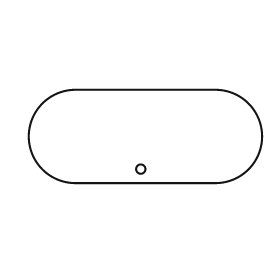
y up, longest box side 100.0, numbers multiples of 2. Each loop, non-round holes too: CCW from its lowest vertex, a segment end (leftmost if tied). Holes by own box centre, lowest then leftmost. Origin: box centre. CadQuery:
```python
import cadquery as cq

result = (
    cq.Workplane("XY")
    .moveTo(-30.0, -20.0)
    .lineTo(30.0, -20.0)
    .threePointArc((50.0, 0.0), (30.0, 20.0))
    .lineTo(-30.0, 20.0)
    .threePointArc((-50.0, 0.0), (-30.0, -20.0))
    .close()
    .moveTo(-2.0, -14.0)
    .circle(2.0)
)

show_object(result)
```